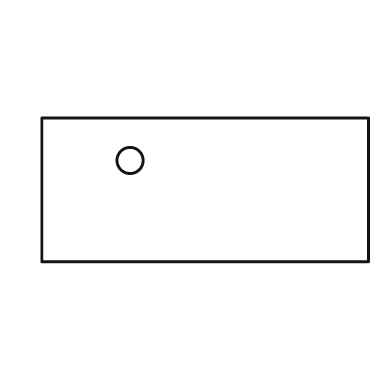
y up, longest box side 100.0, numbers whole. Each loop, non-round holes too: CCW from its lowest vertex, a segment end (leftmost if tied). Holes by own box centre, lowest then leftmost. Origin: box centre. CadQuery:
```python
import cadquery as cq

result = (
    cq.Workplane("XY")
    .moveTo(-50.0, -22.0)
    .lineTo(50.0, -22.0)
    .lineTo(50.0, 22.0)
    .lineTo(-50.0, 22.0)
    .close()
    .moveTo(-23.0, 9.0)
    .circle(4.0)
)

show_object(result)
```